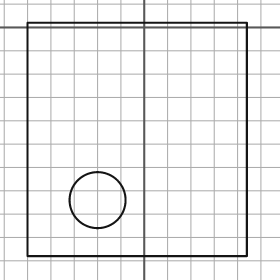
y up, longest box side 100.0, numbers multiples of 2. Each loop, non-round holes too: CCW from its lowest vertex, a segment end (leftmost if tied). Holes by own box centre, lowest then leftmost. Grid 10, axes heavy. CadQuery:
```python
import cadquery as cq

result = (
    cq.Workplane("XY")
    .moveTo(-50.0, -98.0)
    .lineTo(44.0, -98.0)
    .lineTo(44.0, 2.0)
    .lineTo(-50.0, 2.0)
    .close()
    .moveTo(-20.0, -74.0)
    .circle(12.0)
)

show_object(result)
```